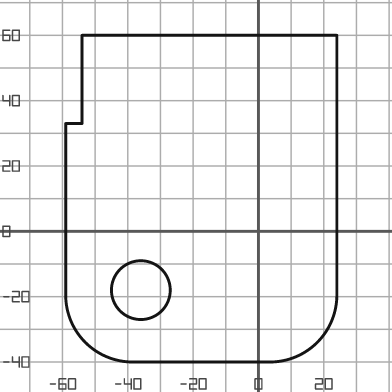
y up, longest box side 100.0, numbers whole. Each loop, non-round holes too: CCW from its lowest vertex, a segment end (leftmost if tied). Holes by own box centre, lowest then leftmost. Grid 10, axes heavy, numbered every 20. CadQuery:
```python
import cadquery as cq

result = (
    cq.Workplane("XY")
    .moveTo(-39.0, -40.0)
    .lineTo(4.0, -40.0)
    .threePointArc((18.0, -34.0), (24.0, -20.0))
    .lineTo(24.0, 60.0)
    .lineTo(-54.0, 60.0)
    .lineTo(-54.0, 33.0)
    .lineTo(-59.0, 33.0)
    .lineTo(-59.0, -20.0)
    .threePointArc((-53.0, -34.0), (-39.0, -40.0))
    .close()
    .moveTo(-36.0, -18.0)
    .circle(9.0)
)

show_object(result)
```